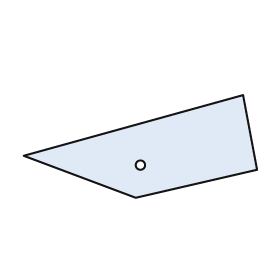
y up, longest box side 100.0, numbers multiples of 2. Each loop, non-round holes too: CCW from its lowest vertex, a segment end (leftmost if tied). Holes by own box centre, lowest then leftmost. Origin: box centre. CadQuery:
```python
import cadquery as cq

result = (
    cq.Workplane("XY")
    .moveTo(-2.0, -22.0)
    .lineTo(50.0, -10.0)
    .lineTo(44.0, 22.0)
    .lineTo(-50.0, -4.0)
    .close()
    .moveTo(0.0, -8.0)
    .circle(2.0)
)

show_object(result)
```